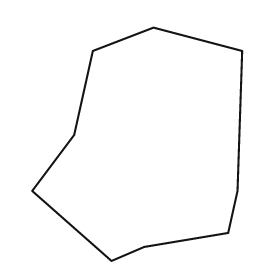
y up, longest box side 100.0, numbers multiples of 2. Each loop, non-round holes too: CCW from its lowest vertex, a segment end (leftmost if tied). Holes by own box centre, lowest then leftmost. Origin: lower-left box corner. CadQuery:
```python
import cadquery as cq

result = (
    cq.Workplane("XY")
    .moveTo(34.0, 0.0)
    .lineTo(48.0, 6.0)
    .lineTo(84.0, 12.0)
    .lineTo(88.0, 30.0)
    .lineTo(90.0, 90.0)
    .lineTo(52.0, 100.0)
    .lineTo(26.0, 90.0)
    .lineTo(18.0, 54.0)
    .lineTo(0.0, 30.0)
    .close()
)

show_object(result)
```